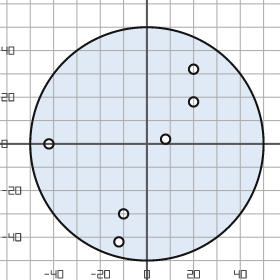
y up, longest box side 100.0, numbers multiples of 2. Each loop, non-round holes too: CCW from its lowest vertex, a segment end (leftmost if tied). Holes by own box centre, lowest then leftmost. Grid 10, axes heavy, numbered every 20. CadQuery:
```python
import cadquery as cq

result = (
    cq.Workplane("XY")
    .moveTo(0.0, 0.0)
    .circle(50.0)
    .moveTo(-12.0, -42.0)
    .circle(2.0)
    .moveTo(-10.0, -30.0)
    .circle(2.0)
    .moveTo(-42.0, 0.0)
    .circle(2.0)
    .moveTo(8.0, 2.0)
    .circle(2.0)
    .moveTo(20.0, 18.0)
    .circle(2.0)
    .moveTo(20.0, 32.0)
    .circle(2.0)
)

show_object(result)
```